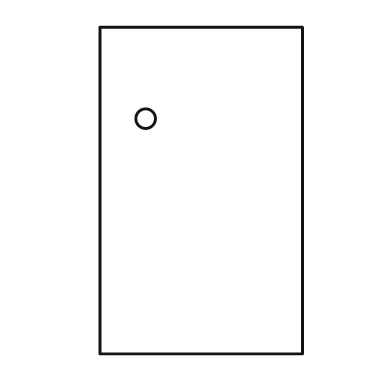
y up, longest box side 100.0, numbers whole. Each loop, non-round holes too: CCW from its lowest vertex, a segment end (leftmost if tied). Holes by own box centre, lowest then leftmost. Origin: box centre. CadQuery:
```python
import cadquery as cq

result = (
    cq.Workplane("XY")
    .moveTo(-31.0, -50.0)
    .lineTo(31.0, -50.0)
    .lineTo(31.0, 50.0)
    .lineTo(-31.0, 50.0)
    .close()
    .moveTo(-17.0, 22.0)
    .circle(3.0)
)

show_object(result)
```